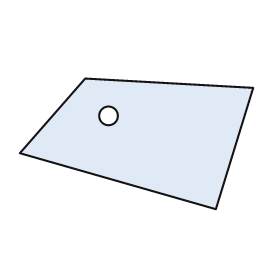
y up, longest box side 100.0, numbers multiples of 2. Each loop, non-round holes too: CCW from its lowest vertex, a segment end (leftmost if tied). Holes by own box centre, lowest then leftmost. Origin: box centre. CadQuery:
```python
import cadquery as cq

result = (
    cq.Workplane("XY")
    .moveTo(34.0, -28.0)
    .lineTo(50.0, 24.0)
    .lineTo(-22.0, 28.0)
    .lineTo(-50.0, -4.0)
    .close()
    .moveTo(-12.0, 12.0)
    .circle(4.0)
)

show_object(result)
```